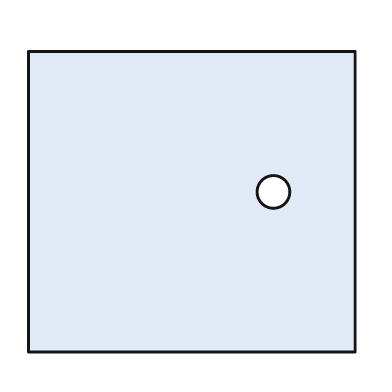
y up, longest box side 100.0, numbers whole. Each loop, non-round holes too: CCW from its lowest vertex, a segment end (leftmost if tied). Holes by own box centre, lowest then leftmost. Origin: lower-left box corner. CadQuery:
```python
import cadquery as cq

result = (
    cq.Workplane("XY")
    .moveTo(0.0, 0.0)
    .lineTo(100.0, 0.0)
    .lineTo(100.0, 92.0)
    .lineTo(0.0, 92.0)
    .close()
    .moveTo(75.0, 49.0)
    .circle(5.0)
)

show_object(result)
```